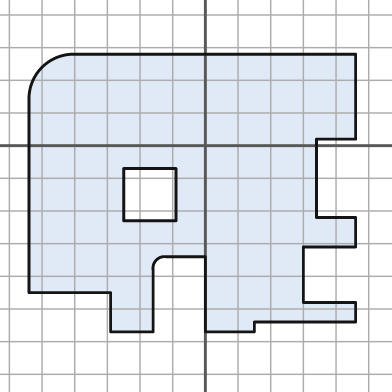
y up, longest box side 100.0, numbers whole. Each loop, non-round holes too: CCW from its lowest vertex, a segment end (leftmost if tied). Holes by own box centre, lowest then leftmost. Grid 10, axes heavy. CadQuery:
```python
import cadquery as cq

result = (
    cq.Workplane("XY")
    .moveTo(-29.0, -57.0)
    .lineTo(-16.0, -57.0)
    .lineTo(-16.0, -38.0)
    .threePointArc((-15.0, -35.0), (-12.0, -34.0))
    .lineTo(0.0, -34.0)
    .lineTo(0.0, -57.0)
    .lineTo(15.0, -57.0)
    .lineTo(15.0, -54.0)
    .lineTo(46.0, -54.0)
    .lineTo(46.0, -48.0)
    .lineTo(30.0, -48.0)
    .lineTo(30.0, -31.0)
    .lineTo(46.0, -31.0)
    .lineTo(46.0, -22.0)
    .lineTo(34.0, -22.0)
    .lineTo(34.0, 2.0)
    .lineTo(46.0, 2.0)
    .lineTo(46.0, 28.0)
    .lineTo(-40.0, 28.0)
    .threePointArc((-50.0, 24.0), (-54.0, 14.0))
    .lineTo(-54.0, -45.0)
    .lineTo(-29.0, -45.0)
    .close()
    .moveTo(-25.0, -23.0)
    .lineTo(-9.0, -23.0)
    .lineTo(-9.0, -7.0)
    .lineTo(-25.0, -7.0)
    .close()
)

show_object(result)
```